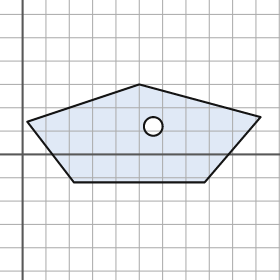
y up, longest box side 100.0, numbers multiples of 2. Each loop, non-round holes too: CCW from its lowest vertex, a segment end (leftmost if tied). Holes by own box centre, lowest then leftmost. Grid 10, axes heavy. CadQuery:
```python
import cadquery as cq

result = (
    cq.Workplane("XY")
    .moveTo(22.0, -12.0)
    .lineTo(78.0, -12.0)
    .lineTo(102.0, 16.0)
    .lineTo(50.0, 30.0)
    .lineTo(2.0, 14.0)
    .close()
    .moveTo(56.0, 12.0)
    .circle(4.0)
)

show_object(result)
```